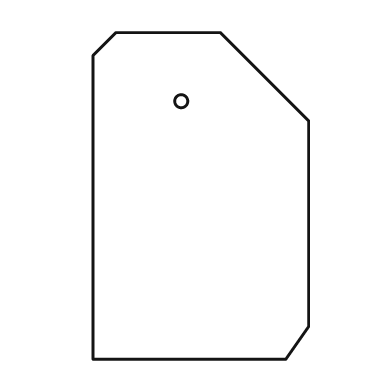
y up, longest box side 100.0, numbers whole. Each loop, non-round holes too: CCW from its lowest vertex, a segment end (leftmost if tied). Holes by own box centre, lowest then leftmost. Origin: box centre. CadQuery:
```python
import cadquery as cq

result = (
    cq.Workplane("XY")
    .moveTo(-33.0, -50.0)
    .lineTo(26.0, -50.0)
    .lineTo(33.0, -40.0)
    .lineTo(33.0, 23.0)
    .lineTo(6.0, 50.0)
    .lineTo(-26.0, 50.0)
    .lineTo(-33.0, 43.0)
    .close()
    .moveTo(-6.0, 29.0)
    .circle(2.0)
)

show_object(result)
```